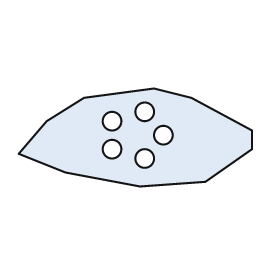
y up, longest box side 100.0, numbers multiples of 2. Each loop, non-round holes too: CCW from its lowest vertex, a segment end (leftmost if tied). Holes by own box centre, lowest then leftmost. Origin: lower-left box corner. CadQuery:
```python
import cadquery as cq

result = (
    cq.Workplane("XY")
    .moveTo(52.0, 0.0)
    .lineTo(80.0, 2.0)
    .lineTo(100.0, 16.0)
    .lineTo(100.0, 24.0)
    .lineTo(74.0, 38.0)
    .lineTo(58.0, 42.0)
    .lineTo(28.0, 38.0)
    .lineTo(12.0, 28.0)
    .lineTo(0.0, 14.0)
    .lineTo(20.0, 6.0)
    .close()
    .moveTo(54.0, 12.0)
    .circle(4.0)
    .moveTo(40.0, 16.0)
    .circle(4.0)
    .moveTo(62.0, 22.0)
    .circle(4.0)
    .moveTo(40.0, 28.0)
    .circle(4.0)
    .moveTo(54.0, 32.0)
    .circle(4.0)
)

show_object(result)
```